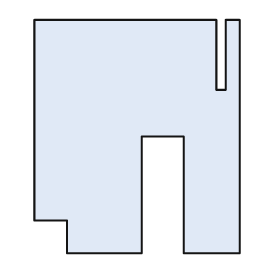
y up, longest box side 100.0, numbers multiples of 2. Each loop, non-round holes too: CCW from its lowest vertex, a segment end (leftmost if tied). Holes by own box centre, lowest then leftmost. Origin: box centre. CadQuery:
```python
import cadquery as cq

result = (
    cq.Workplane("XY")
    .moveTo(-30.0, -50.0)
    .lineTo(2.0, -50.0)
    .lineTo(2.0, 0.0)
    .lineTo(20.0, 0.0)
    .lineTo(20.0, -50.0)
    .lineTo(44.0, -50.0)
    .lineTo(44.0, 50.0)
    .lineTo(38.0, 50.0)
    .lineTo(38.0, 20.0)
    .lineTo(34.0, 20.0)
    .lineTo(34.0, 50.0)
    .lineTo(-44.0, 50.0)
    .lineTo(-44.0, -36.0)
    .lineTo(-30.0, -36.0)
    .close()
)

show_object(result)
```